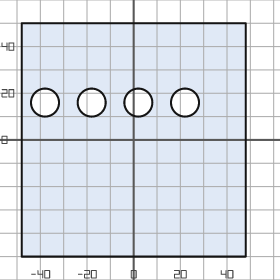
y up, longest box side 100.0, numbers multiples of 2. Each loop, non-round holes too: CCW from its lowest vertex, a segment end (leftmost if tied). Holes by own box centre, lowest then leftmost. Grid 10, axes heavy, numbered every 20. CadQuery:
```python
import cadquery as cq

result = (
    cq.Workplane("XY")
    .moveTo(-48.0, -50.0)
    .lineTo(48.0, -50.0)
    .lineTo(48.0, 50.0)
    .lineTo(-48.0, 50.0)
    .close()
    .moveTo(-38.0, 16.0)
    .circle(6.0)
    .moveTo(-18.0, 16.0)
    .circle(6.0)
    .moveTo(2.0, 16.0)
    .circle(6.0)
    .moveTo(22.0, 16.0)
    .circle(6.0)
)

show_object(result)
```